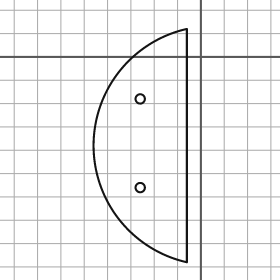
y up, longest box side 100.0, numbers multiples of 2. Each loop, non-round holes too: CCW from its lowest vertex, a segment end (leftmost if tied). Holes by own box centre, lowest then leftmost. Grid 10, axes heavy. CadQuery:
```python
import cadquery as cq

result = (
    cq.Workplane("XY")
    .moveTo(-6.0, -88.0)
    .lineTo(-6.0, 12.0)
    .threePointArc((-46.0, -38.0), (-6.0, -88.0))
    .close()
    .moveTo(-26.0, -56.0)
    .circle(2.0)
    .moveTo(-26.0, -18.0)
    .circle(2.0)
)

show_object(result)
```